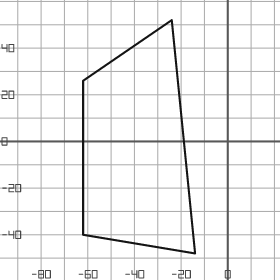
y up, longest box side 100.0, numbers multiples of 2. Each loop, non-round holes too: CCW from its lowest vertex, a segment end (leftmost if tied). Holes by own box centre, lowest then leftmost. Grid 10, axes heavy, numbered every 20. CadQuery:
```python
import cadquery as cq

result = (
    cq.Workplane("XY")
    .moveTo(-14.0, -48.0)
    .lineTo(-24.0, 52.0)
    .lineTo(-62.0, 26.0)
    .lineTo(-62.0, -40.0)
    .close()
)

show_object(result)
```